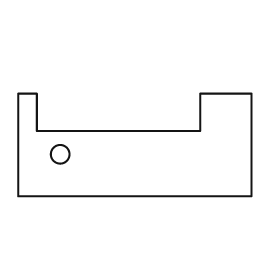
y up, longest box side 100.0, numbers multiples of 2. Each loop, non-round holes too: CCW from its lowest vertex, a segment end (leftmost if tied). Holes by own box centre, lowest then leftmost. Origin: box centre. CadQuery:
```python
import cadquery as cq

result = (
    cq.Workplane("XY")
    .moveTo(-50.0, -22.0)
    .lineTo(50.0, -22.0)
    .lineTo(50.0, 22.0)
    .lineTo(28.0, 22.0)
    .lineTo(28.0, 6.0)
    .lineTo(-42.0, 6.0)
    .lineTo(-42.0, 22.0)
    .lineTo(-50.0, 22.0)
    .close()
    .moveTo(-32.0, -4.0)
    .circle(4.0)
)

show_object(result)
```